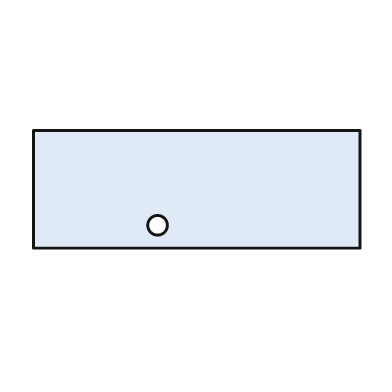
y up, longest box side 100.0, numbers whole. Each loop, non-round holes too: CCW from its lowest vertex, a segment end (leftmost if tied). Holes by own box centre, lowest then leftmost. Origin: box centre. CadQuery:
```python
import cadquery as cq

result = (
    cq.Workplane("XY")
    .moveTo(-50.0, -18.0)
    .lineTo(50.0, -18.0)
    .lineTo(50.0, 18.0)
    .lineTo(-50.0, 18.0)
    .close()
    .moveTo(-12.0, -11.0)
    .circle(3.0)
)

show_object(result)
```